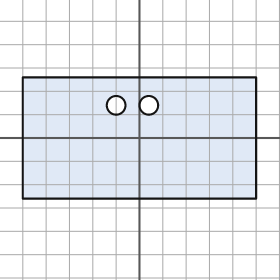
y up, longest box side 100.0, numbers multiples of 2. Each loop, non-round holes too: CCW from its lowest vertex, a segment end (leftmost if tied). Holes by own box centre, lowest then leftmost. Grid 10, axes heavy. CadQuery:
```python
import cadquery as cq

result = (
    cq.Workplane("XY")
    .moveTo(-50.0, -26.0)
    .lineTo(50.0, -26.0)
    .lineTo(50.0, 26.0)
    .lineTo(-50.0, 26.0)
    .close()
    .moveTo(-10.0, 14.0)
    .circle(4.0)
    .moveTo(4.0, 14.0)
    .circle(4.0)
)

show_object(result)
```